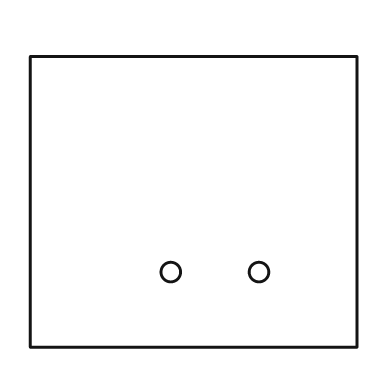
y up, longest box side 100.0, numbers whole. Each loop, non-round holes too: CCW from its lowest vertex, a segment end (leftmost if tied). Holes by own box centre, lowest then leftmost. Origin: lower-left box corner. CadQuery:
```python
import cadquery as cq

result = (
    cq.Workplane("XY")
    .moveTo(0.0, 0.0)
    .lineTo(100.0, 0.0)
    .lineTo(100.0, 89.0)
    .lineTo(0.0, 89.0)
    .close()
    .moveTo(43.0, 23.0)
    .circle(3.0)
    .moveTo(70.0, 23.0)
    .circle(3.0)
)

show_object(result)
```